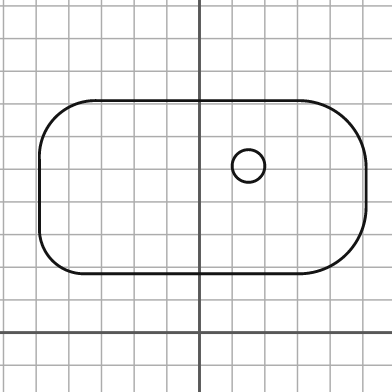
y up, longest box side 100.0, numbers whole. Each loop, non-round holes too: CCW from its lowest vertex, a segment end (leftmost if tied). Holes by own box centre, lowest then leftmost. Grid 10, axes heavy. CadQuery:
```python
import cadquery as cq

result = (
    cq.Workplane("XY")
    .moveTo(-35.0, 18.0)
    .lineTo(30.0, 18.0)
    .threePointArc((45.0, 24.0), (51.0, 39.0))
    .lineTo(51.0, 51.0)
    .threePointArc((45.0, 65.0), (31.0, 71.0))
    .lineTo(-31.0, 71.0)
    .threePointArc((-44.0, 66.0), (-49.0, 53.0))
    .lineTo(-49.0, 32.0)
    .threePointArc((-45.0, 22.0), (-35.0, 18.0))
    .close()
    .moveTo(15.0, 51.0)
    .circle(5.0)
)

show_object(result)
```